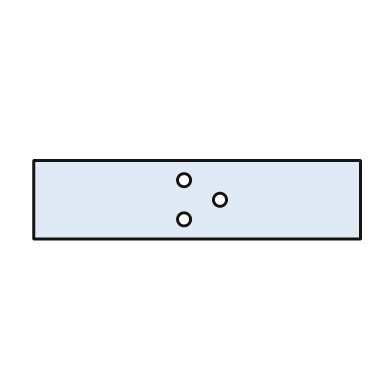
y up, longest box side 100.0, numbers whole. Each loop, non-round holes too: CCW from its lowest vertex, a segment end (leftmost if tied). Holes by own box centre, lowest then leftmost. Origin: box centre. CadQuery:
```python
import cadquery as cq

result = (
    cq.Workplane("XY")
    .moveTo(-50.0, -12.0)
    .lineTo(50.0, -12.0)
    .lineTo(50.0, 12.0)
    .lineTo(-50.0, 12.0)
    .close()
    .moveTo(-4.0, -6.0)
    .circle(2.0)
    .moveTo(7.0, 0.0)
    .circle(2.0)
    .moveTo(-4.0, 6.0)
    .circle(2.0)
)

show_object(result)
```